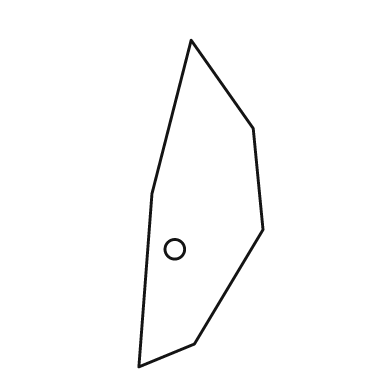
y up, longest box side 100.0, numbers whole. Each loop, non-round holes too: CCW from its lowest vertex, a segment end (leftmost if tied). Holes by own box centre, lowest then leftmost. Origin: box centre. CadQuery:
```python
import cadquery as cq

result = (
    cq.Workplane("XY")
    .moveTo(-19.0, -50.0)
    .lineTo(-2.0, -43.0)
    .lineTo(19.0, -8.0)
    .lineTo(16.0, 23.0)
    .lineTo(-3.0, 50.0)
    .lineTo(-15.0, 3.0)
    .close()
    .moveTo(-8.0, -14.0)
    .circle(3.0)
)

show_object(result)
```